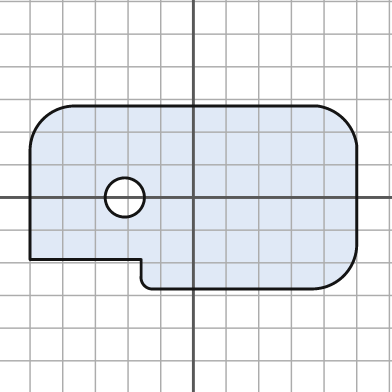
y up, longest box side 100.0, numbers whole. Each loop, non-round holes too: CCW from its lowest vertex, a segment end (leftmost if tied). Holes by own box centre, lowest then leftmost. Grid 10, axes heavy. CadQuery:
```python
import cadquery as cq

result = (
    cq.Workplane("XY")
    .moveTo(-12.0, -28.0)
    .lineTo(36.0, -28.0)
    .threePointArc((46.0, -24.0), (50.0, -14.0))
    .lineTo(50.0, 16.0)
    .threePointArc((46.0, 24.0), (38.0, 28.0))
    .lineTo(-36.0, 28.0)
    .threePointArc((-46.0, 24.0), (-50.0, 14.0))
    .lineTo(-50.0, -19.0)
    .lineTo(-16.0, -19.0)
    .lineTo(-16.0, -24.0)
    .threePointArc((-15.0, -27.0), (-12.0, -28.0))
    .close()
    .moveTo(-21.0, 0.0)
    .circle(6.0)
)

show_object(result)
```